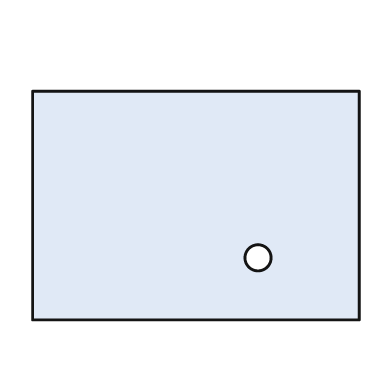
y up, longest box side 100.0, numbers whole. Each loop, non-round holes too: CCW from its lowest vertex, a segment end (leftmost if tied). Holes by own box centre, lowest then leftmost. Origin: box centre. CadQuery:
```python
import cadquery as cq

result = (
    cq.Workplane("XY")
    .moveTo(-50.0, -35.0)
    .lineTo(50.0, -35.0)
    .lineTo(50.0, 35.0)
    .lineTo(-50.0, 35.0)
    .close()
    .moveTo(19.0, -16.0)
    .circle(4.0)
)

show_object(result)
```